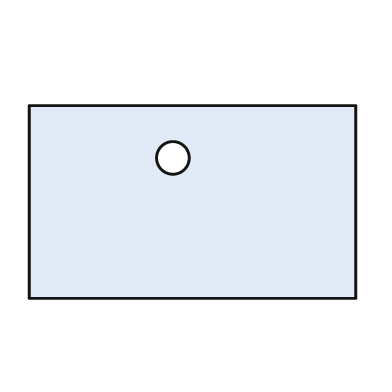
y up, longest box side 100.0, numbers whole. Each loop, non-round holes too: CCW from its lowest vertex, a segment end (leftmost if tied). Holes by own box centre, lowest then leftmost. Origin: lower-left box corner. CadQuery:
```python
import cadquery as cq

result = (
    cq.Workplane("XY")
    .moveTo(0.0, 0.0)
    .lineTo(100.0, 0.0)
    .lineTo(100.0, 59.0)
    .lineTo(0.0, 59.0)
    .close()
    .moveTo(44.0, 43.0)
    .circle(5.0)
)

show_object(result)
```